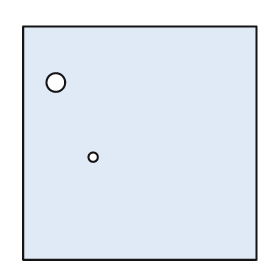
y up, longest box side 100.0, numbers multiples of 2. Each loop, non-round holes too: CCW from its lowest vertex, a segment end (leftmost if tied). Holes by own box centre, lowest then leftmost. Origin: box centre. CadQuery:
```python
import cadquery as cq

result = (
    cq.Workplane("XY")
    .moveTo(-50.0, -50.0)
    .lineTo(50.0, -50.0)
    .lineTo(50.0, 50.0)
    .lineTo(-50.0, 50.0)
    .close()
    .moveTo(-20.0, -6.0)
    .circle(2.0)
    .moveTo(-36.0, 26.0)
    .circle(4.0)
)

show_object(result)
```